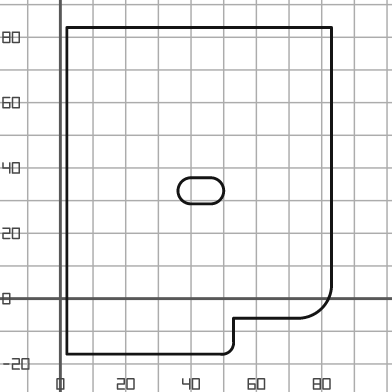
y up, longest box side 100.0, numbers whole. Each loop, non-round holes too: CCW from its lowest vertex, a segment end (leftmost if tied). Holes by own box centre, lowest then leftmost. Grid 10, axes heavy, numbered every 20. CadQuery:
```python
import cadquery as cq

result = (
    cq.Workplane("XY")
    .moveTo(2.0, -17.0)
    .lineTo(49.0, -17.0)
    .threePointArc((52.0, -16.0), (53.0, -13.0))
    .lineTo(53.0, -6.0)
    .lineTo(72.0, -6.0)
    .threePointArc((80.0, -3.0), (83.0, 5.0))
    .lineTo(83.0, 83.0)
    .lineTo(2.0, 83.0)
    .close()
    .moveTo(40.0, 29.0)
    .lineTo(46.0, 29.0)
    .threePointArc((50.0, 33.0), (46.0, 37.0))
    .lineTo(40.0, 37.0)
    .threePointArc((36.0, 33.0), (40.0, 29.0))
    .close()
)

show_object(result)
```